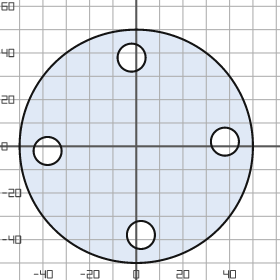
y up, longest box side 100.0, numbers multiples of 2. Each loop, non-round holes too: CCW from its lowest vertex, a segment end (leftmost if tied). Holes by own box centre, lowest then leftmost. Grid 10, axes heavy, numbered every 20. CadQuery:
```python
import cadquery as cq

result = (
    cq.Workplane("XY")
    .moveTo(0.0, 0.0)
    .circle(50.0)
    .moveTo(2.0, -38.0)
    .circle(6.0)
    .moveTo(-38.0, -2.0)
    .circle(6.0)
    .moveTo(38.0, 2.0)
    .circle(6.0)
    .moveTo(-2.0, 38.0)
    .circle(6.0)
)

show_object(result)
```